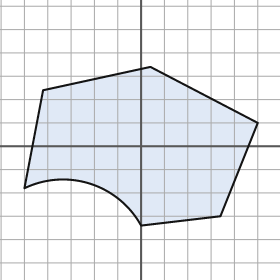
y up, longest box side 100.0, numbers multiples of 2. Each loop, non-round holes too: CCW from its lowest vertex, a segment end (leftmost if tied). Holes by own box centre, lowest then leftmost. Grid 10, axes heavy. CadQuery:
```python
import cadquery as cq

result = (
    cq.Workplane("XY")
    .moveTo(0.0, -34.0)
    .lineTo(34.0, -30.0)
    .lineTo(50.0, 10.0)
    .lineTo(4.0, 34.0)
    .lineTo(-42.0, 24.0)
    .lineTo(-50.0, -18.0)
    .threePointArc((-22.0, -16.0), (0.0, -34.0))
    .close()
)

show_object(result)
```